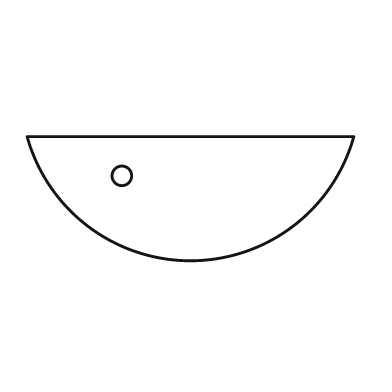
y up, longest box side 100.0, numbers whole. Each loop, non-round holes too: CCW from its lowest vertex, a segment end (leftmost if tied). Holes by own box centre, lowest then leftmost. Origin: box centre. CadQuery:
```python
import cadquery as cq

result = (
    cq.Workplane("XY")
    .moveTo(-50.0, 19.0)
    .threePointArc((0.0, -19.0), (50.0, 19.0))
    .close()
    .moveTo(-21.0, 7.0)
    .circle(3.0)
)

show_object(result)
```